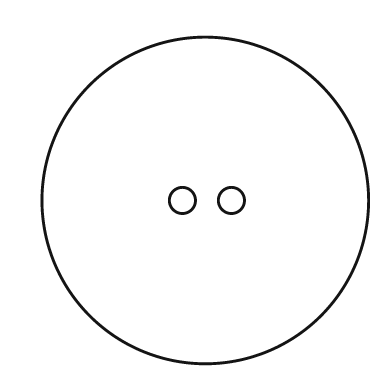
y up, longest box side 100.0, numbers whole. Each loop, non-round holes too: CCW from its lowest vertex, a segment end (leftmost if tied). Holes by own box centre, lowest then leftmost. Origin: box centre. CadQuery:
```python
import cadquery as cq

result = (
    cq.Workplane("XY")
    .moveTo(0.0, 0.0)
    .circle(50.0)
    .moveTo(-7.0, 0.0)
    .circle(4.0)
    .moveTo(8.0, 0.0)
    .circle(4.0)
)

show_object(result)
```